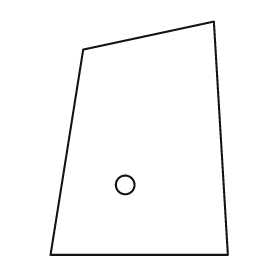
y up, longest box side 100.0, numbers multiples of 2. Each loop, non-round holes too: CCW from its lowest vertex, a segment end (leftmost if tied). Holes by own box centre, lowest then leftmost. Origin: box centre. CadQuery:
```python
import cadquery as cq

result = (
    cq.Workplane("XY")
    .moveTo(-38.0, -50.0)
    .lineTo(38.0, -50.0)
    .lineTo(32.0, 50.0)
    .lineTo(-24.0, 38.0)
    .close()
    .moveTo(-6.0, -20.0)
    .circle(4.0)
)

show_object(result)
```